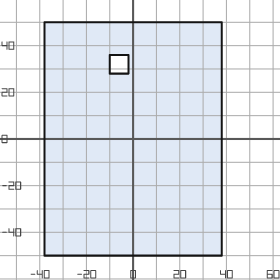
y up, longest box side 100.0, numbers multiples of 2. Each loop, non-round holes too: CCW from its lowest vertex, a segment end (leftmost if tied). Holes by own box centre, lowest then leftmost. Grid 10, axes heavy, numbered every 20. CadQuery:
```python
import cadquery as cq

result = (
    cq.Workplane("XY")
    .moveTo(-38.0, -50.0)
    .lineTo(38.0, -50.0)
    .lineTo(38.0, 50.0)
    .lineTo(-38.0, 50.0)
    .close()
    .moveTo(-10.0, 28.0)
    .lineTo(-2.0, 28.0)
    .lineTo(-2.0, 36.0)
    .lineTo(-10.0, 36.0)
    .close()
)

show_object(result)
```